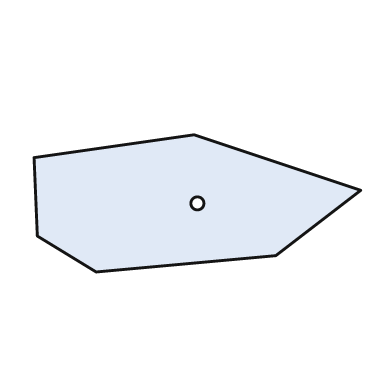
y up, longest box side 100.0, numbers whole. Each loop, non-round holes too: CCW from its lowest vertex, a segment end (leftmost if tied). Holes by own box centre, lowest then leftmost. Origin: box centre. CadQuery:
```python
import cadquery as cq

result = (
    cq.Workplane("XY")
    .moveTo(-31.0, -21.0)
    .lineTo(24.0, -16.0)
    .lineTo(50.0, 4.0)
    .lineTo(-1.0, 21.0)
    .lineTo(-50.0, 14.0)
    .lineTo(-49.0, -10.0)
    .close()
    .moveTo(0.0, 0.0)
    .circle(2.0)
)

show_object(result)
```